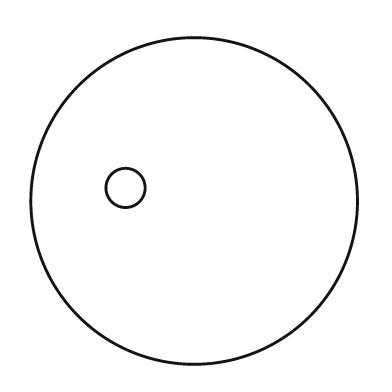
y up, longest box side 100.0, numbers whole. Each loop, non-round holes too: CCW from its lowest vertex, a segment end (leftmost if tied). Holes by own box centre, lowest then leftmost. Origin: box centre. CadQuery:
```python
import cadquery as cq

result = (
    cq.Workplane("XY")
    .moveTo(0.0, 0.0)
    .circle(50.0)
    .moveTo(-21.0, 4.0)
    .circle(6.0)
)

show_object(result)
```